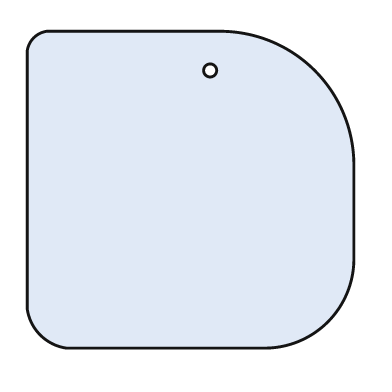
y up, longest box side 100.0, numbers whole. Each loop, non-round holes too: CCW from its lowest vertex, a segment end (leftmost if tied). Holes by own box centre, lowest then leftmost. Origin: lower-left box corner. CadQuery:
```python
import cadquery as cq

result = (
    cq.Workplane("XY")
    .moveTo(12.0, 0.0)
    .lineTo(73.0, 0.0)
    .threePointArc((92.0, 8.0), (100.0, 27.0))
    .lineTo(100.0, 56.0)
    .threePointArc((88.0, 85.0), (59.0, 97.0))
    .lineTo(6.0, 97.0)
    .threePointArc((2.0, 95.0), (0.0, 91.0))
    .lineTo(0.0, 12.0)
    .threePointArc((4.0, 4.0), (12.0, 0.0))
    .close()
    .moveTo(56.0, 85.0)
    .circle(2.0)
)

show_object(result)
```